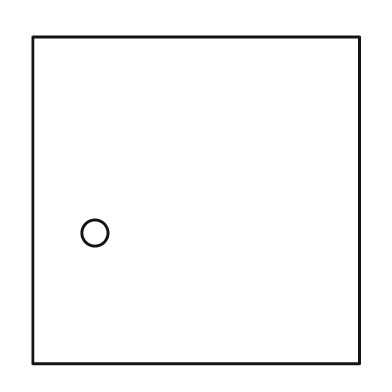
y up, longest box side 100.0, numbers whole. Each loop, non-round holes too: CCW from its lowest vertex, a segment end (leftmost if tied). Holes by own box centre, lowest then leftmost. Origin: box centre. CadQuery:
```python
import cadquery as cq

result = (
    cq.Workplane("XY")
    .moveTo(-50.0, -50.0)
    .lineTo(50.0, -50.0)
    .lineTo(50.0, 50.0)
    .lineTo(-50.0, 50.0)
    .close()
    .moveTo(-31.0, -10.0)
    .circle(4.0)
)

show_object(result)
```